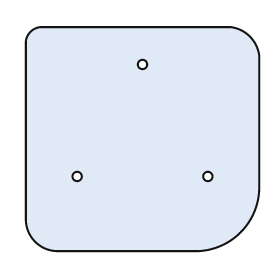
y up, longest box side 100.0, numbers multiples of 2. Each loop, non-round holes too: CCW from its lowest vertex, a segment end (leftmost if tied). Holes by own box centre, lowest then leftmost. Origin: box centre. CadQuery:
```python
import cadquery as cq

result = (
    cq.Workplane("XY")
    .moveTo(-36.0, -48.0)
    .lineTo(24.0, -48.0)
    .threePointArc((42.0, -40.0), (50.0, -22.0))
    .lineTo(50.0, 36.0)
    .threePointArc((46.0, 44.0), (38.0, 48.0))
    .lineTo(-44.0, 48.0)
    .threePointArc((-48.0, 46.0), (-50.0, 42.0))
    .lineTo(-50.0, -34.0)
    .threePointArc((-46.0, -44.0), (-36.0, -48.0))
    .close()
    .moveTo(-28.0, -16.0)
    .circle(2.0)
    .moveTo(28.0, -16.0)
    .circle(2.0)
    .moveTo(0.0, 32.0)
    .circle(2.0)
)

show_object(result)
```